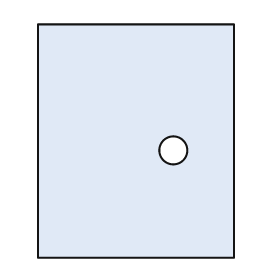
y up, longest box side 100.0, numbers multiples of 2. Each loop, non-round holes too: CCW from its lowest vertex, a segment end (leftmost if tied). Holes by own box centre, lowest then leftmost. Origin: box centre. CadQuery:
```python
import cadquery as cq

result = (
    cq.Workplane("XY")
    .moveTo(-42.0, -50.0)
    .lineTo(42.0, -50.0)
    .lineTo(42.0, 50.0)
    .lineTo(-42.0, 50.0)
    .close()
    .moveTo(16.0, -4.0)
    .circle(6.0)
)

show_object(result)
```